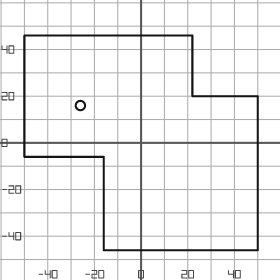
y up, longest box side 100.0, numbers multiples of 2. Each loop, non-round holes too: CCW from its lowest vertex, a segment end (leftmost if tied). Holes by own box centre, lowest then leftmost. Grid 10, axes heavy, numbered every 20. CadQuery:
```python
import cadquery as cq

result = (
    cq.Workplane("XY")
    .moveTo(-16.0, -46.0)
    .lineTo(50.0, -46.0)
    .lineTo(50.0, 20.0)
    .lineTo(22.0, 20.0)
    .lineTo(22.0, 46.0)
    .lineTo(-50.0, 46.0)
    .lineTo(-50.0, -6.0)
    .lineTo(-16.0, -6.0)
    .close()
    .moveTo(-26.0, 16.0)
    .circle(2.0)
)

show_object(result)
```